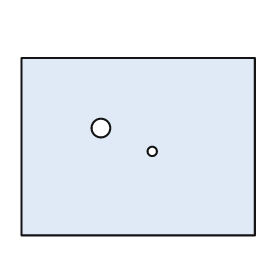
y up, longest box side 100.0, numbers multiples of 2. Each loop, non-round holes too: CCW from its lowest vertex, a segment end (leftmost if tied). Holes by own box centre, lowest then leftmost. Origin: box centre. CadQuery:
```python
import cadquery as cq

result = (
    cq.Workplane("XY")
    .moveTo(-50.0, -38.0)
    .lineTo(50.0, -38.0)
    .lineTo(50.0, 38.0)
    .lineTo(-50.0, 38.0)
    .close()
    .moveTo(6.0, -2.0)
    .circle(2.0)
    .moveTo(-16.0, 8.0)
    .circle(4.0)
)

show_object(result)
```